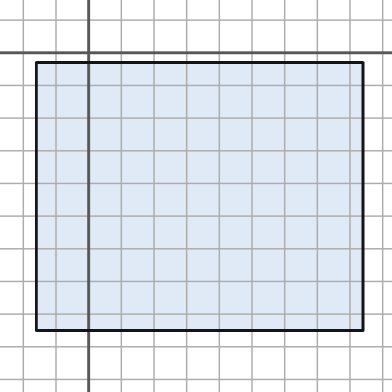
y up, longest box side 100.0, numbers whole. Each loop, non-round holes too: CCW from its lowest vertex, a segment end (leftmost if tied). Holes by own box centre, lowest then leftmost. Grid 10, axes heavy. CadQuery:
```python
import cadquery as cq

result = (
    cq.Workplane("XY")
    .moveTo(-16.0, -85.0)
    .lineTo(84.0, -85.0)
    .lineTo(84.0, -3.0)
    .lineTo(-16.0, -3.0)
    .close()
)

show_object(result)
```